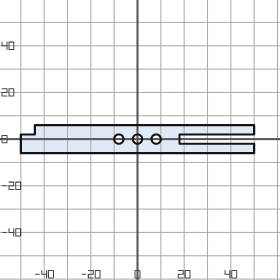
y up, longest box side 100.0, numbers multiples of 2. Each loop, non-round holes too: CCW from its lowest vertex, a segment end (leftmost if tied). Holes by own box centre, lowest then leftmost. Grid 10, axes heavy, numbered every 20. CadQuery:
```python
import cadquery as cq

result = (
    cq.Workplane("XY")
    .moveTo(-50.0, -6.0)
    .lineTo(50.0, -6.0)
    .lineTo(50.0, -2.0)
    .lineTo(18.0, -2.0)
    .lineTo(18.0, 2.0)
    .lineTo(50.0, 2.0)
    .lineTo(50.0, 6.0)
    .lineTo(-44.0, 6.0)
    .lineTo(-44.0, 2.0)
    .lineTo(-50.0, 2.0)
    .close()
    .moveTo(-8.0, 0.0)
    .circle(2.0)
    .moveTo(0.0, 0.0)
    .circle(2.0)
    .moveTo(8.0, 0.0)
    .circle(2.0)
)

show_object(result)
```